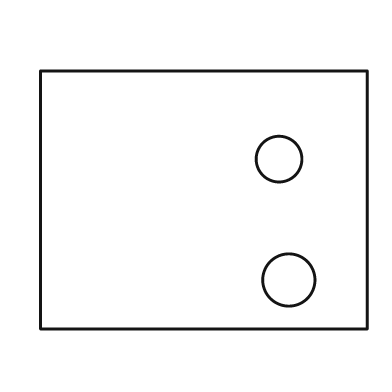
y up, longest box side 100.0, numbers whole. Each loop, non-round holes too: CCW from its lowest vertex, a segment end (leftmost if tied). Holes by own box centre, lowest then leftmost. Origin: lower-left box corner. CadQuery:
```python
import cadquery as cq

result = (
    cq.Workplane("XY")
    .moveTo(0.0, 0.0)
    .lineTo(100.0, 0.0)
    .lineTo(100.0, 79.0)
    .lineTo(0.0, 79.0)
    .close()
    .moveTo(76.0, 15.0)
    .circle(8.0)
    .moveTo(73.0, 52.0)
    .circle(7.0)
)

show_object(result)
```